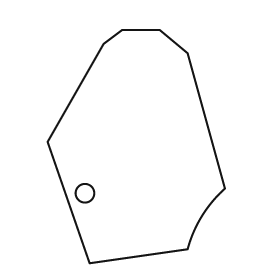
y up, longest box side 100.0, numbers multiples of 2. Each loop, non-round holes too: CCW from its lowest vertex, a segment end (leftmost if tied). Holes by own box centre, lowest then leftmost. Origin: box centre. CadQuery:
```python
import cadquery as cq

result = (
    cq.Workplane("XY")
    .moveTo(-20.0, -50.0)
    .lineTo(22.0, -44.0)
    .threePointArc((28.0, -30.0), (38.0, -18.0))
    .lineTo(22.0, 40.0)
    .lineTo(10.0, 50.0)
    .lineTo(-6.0, 50.0)
    .lineTo(-14.0, 44.0)
    .lineTo(-38.0, 2.0)
    .close()
    .moveTo(-22.0, -20.0)
    .circle(4.0)
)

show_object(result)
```